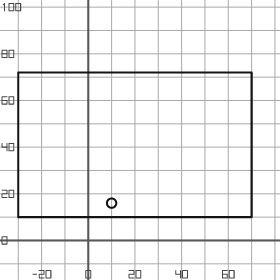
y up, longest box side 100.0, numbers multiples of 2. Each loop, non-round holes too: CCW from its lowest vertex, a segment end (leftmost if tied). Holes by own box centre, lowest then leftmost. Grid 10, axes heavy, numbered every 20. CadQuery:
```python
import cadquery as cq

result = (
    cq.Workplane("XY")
    .moveTo(-30.0, 10.0)
    .lineTo(70.0, 10.0)
    .lineTo(70.0, 72.0)
    .lineTo(-30.0, 72.0)
    .close()
    .moveTo(10.0, 16.0)
    .circle(2.0)
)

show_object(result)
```